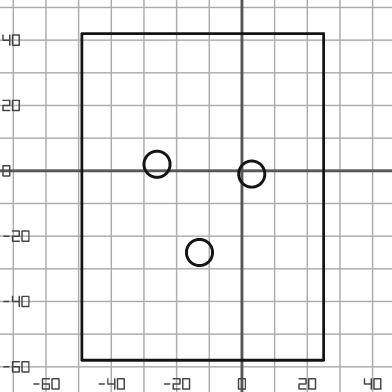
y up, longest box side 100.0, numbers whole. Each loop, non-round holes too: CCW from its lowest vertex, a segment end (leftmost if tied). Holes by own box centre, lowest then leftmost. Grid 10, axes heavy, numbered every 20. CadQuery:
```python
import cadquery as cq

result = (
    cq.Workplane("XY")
    .moveTo(-49.0, -58.0)
    .lineTo(25.0, -58.0)
    .lineTo(25.0, 42.0)
    .lineTo(-49.0, 42.0)
    .close()
    .moveTo(-13.0, -25.0)
    .circle(4.0)
    .moveTo(3.0, -1.0)
    .circle(4.0)
    .moveTo(-26.0, 2.0)
    .circle(4.0)
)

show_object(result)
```